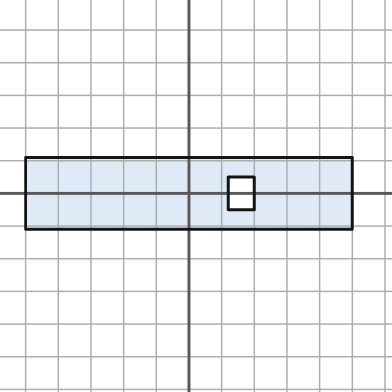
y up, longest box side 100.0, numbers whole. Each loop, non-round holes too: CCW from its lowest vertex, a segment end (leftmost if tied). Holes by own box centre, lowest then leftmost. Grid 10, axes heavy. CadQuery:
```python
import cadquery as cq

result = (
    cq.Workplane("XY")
    .moveTo(-50.0, -11.0)
    .lineTo(50.0, -11.0)
    .lineTo(50.0, 11.0)
    .lineTo(-50.0, 11.0)
    .close()
    .moveTo(12.0, -5.0)
    .lineTo(20.0, -5.0)
    .lineTo(20.0, 5.0)
    .lineTo(12.0, 5.0)
    .close()
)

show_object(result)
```